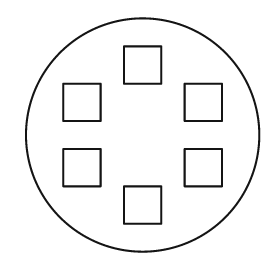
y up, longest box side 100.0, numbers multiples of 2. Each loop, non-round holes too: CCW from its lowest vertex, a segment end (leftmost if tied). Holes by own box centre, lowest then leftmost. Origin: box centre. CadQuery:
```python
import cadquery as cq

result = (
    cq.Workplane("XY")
    .moveTo(0.0, 0.0)
    .circle(50.0)
    .moveTo(-8.0, -38.0)
    .lineTo(8.0, -38.0)
    .lineTo(8.0, -22.0)
    .lineTo(-8.0, -22.0)
    .close()
    .moveTo(-34.0, -22.0)
    .lineTo(-18.0, -22.0)
    .lineTo(-18.0, -6.0)
    .lineTo(-34.0, -6.0)
    .close()
    .moveTo(18.0, -22.0)
    .lineTo(34.0, -22.0)
    .lineTo(34.0, -6.0)
    .lineTo(18.0, -6.0)
    .close()
    .moveTo(-34.0, 6.0)
    .lineTo(-18.0, 6.0)
    .lineTo(-18.0, 22.0)
    .lineTo(-34.0, 22.0)
    .close()
    .moveTo(18.0, 6.0)
    .lineTo(34.0, 6.0)
    .lineTo(34.0, 22.0)
    .lineTo(18.0, 22.0)
    .close()
    .moveTo(-8.0, 22.0)
    .lineTo(8.0, 22.0)
    .lineTo(8.0, 38.0)
    .lineTo(-8.0, 38.0)
    .close()
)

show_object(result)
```